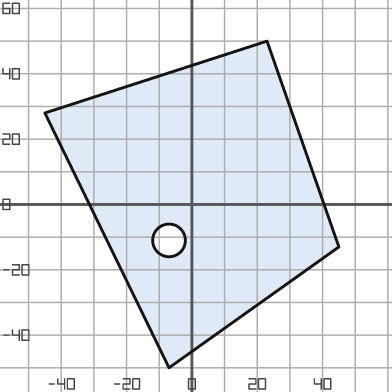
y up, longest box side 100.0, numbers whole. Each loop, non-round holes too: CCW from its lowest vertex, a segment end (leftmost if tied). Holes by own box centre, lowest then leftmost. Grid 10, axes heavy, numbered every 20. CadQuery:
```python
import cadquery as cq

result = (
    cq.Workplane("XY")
    .moveTo(-7.0, -50.0)
    .lineTo(45.0, -13.0)
    .lineTo(23.0, 50.0)
    .lineTo(-45.0, 28.0)
    .close()
    .moveTo(-7.0, -11.0)
    .circle(5.0)
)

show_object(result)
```